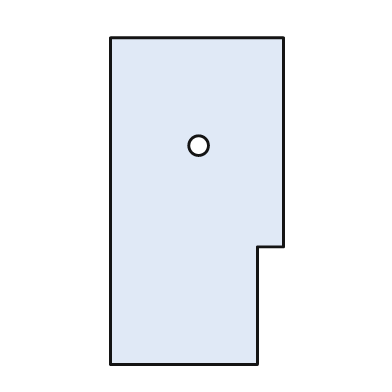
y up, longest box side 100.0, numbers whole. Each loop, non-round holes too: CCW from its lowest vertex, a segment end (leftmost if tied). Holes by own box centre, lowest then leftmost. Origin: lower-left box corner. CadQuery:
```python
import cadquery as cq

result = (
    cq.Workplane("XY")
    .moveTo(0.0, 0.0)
    .lineTo(45.0, 0.0)
    .lineTo(45.0, 36.0)
    .lineTo(53.0, 36.0)
    .lineTo(53.0, 100.0)
    .lineTo(0.0, 100.0)
    .close()
    .moveTo(27.0, 67.0)
    .circle(3.0)
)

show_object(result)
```